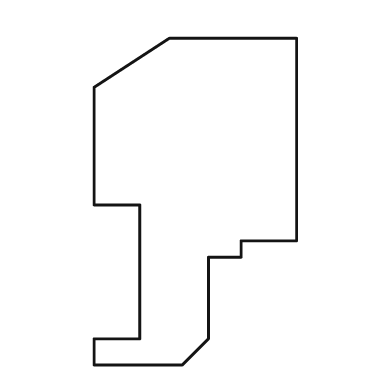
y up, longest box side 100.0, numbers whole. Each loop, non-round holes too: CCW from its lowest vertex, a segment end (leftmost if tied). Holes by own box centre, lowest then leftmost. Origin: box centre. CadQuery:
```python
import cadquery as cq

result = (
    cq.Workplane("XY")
    .moveTo(-31.0, -50.0)
    .lineTo(-4.0, -50.0)
    .lineTo(4.0, -42.0)
    .lineTo(4.0, -17.0)
    .lineTo(14.0, -17.0)
    .lineTo(14.0, -12.0)
    .lineTo(31.0, -12.0)
    .lineTo(31.0, 50.0)
    .lineTo(-8.0, 50.0)
    .lineTo(-31.0, 35.0)
    .lineTo(-31.0, -1.0)
    .lineTo(-17.0, -1.0)
    .lineTo(-17.0, -42.0)
    .lineTo(-31.0, -42.0)
    .close()
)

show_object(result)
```